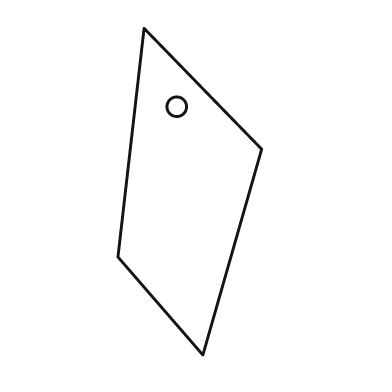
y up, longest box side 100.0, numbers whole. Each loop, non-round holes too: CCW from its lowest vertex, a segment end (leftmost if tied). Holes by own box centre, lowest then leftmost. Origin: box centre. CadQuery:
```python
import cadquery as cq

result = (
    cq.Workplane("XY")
    .moveTo(4.0, -50.0)
    .lineTo(22.0, 13.0)
    .lineTo(-14.0, 50.0)
    .lineTo(-22.0, -20.0)
    .close()
    .moveTo(-4.0, 26.0)
    .circle(3.0)
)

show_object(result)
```